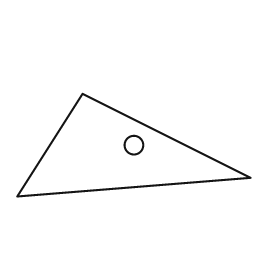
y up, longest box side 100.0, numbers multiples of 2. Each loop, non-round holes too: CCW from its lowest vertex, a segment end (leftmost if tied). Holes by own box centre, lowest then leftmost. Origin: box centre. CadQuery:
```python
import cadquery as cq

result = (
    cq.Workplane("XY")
    .moveTo(-50.0, -22.0)
    .lineTo(50.0, -14.0)
    .lineTo(-22.0, 22.0)
    .close()
    .moveTo(0.0, 0.0)
    .circle(4.0)
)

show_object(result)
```